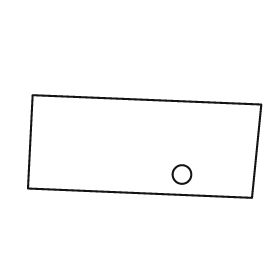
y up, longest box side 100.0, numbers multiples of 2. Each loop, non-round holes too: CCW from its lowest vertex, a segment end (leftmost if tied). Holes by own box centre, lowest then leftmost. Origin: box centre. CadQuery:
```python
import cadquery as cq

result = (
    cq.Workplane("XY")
    .moveTo(46.0, -22.0)
    .lineTo(50.0, 18.0)
    .lineTo(-48.0, 22.0)
    .lineTo(-50.0, -18.0)
    .close()
    .moveTo(16.0, -12.0)
    .circle(4.0)
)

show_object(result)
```